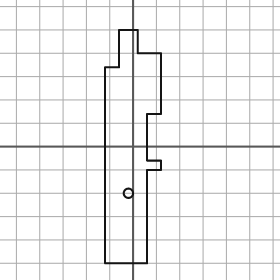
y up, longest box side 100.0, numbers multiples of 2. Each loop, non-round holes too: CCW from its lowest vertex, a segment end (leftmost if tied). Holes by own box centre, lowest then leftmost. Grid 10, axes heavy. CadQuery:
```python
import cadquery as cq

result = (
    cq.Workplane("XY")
    .moveTo(-12.0, -50.0)
    .lineTo(6.0, -50.0)
    .lineTo(6.0, -10.0)
    .lineTo(12.0, -10.0)
    .lineTo(12.0, -6.0)
    .lineTo(6.0, -6.0)
    .lineTo(6.0, 14.0)
    .lineTo(12.0, 14.0)
    .lineTo(12.0, 40.0)
    .lineTo(2.0, 40.0)
    .lineTo(2.0, 50.0)
    .lineTo(-6.0, 50.0)
    .lineTo(-6.0, 34.0)
    .lineTo(-12.0, 34.0)
    .close()
    .moveTo(-2.0, -20.0)
    .circle(2.0)
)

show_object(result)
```